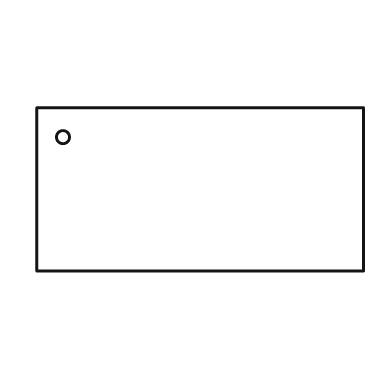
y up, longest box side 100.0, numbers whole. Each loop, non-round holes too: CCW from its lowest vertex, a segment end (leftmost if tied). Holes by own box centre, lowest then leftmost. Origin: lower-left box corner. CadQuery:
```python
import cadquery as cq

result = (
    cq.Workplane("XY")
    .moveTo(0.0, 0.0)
    .lineTo(100.0, 0.0)
    .lineTo(100.0, 50.0)
    .lineTo(0.0, 50.0)
    .close()
    .moveTo(8.0, 41.0)
    .circle(2.0)
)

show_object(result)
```